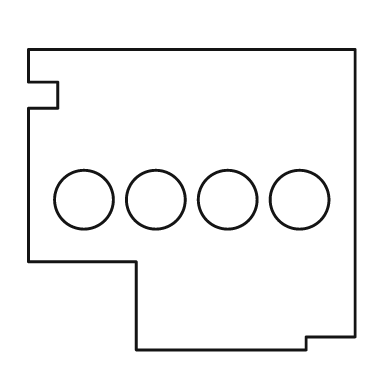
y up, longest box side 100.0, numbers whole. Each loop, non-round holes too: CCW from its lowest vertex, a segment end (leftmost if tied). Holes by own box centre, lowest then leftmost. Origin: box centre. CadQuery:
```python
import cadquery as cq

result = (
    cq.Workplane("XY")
    .moveTo(-17.0, -46.0)
    .lineTo(35.0, -46.0)
    .lineTo(35.0, -42.0)
    .lineTo(50.0, -42.0)
    .lineTo(50.0, 46.0)
    .lineTo(-50.0, 46.0)
    .lineTo(-50.0, 36.0)
    .lineTo(-41.0, 36.0)
    .lineTo(-41.0, 28.0)
    .lineTo(-50.0, 28.0)
    .lineTo(-50.0, -19.0)
    .lineTo(-17.0, -19.0)
    .close()
    .moveTo(-33.0, 0.0)
    .circle(9.0)
    .moveTo(-11.0, 0.0)
    .circle(9.0)
    .moveTo(11.0, 0.0)
    .circle(9.0)
    .moveTo(33.0, 0.0)
    .circle(9.0)
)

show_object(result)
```